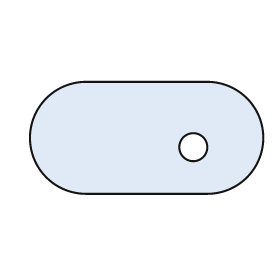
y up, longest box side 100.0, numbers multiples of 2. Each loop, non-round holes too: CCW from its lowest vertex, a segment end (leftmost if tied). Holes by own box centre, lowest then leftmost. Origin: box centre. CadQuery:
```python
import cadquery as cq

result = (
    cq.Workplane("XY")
    .moveTo(-26.0, -24.0)
    .lineTo(26.0, -24.0)
    .threePointArc((50.0, 0.0), (26.0, 24.0))
    .lineTo(-26.0, 24.0)
    .threePointArc((-50.0, 0.0), (-26.0, -24.0))
    .close()
    .moveTo(20.0, -4.0)
    .circle(6.0)
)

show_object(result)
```